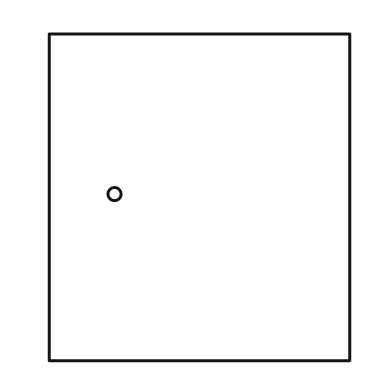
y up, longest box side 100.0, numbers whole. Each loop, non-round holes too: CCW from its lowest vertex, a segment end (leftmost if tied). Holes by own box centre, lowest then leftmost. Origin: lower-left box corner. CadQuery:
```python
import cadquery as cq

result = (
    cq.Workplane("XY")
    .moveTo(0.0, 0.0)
    .lineTo(92.0, 0.0)
    .lineTo(92.0, 100.0)
    .lineTo(0.0, 100.0)
    .close()
    .moveTo(20.0, 51.0)
    .circle(2.0)
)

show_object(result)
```